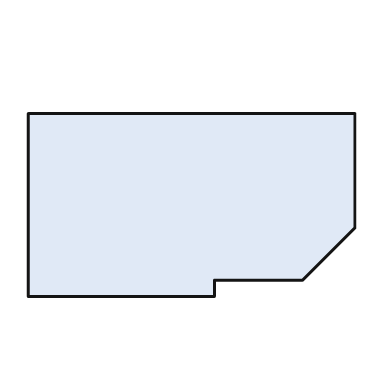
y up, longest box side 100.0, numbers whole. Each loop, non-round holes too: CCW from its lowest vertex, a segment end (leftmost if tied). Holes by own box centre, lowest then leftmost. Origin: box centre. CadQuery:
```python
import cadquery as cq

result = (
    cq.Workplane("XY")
    .moveTo(-50.0, -28.0)
    .lineTo(7.0, -28.0)
    .lineTo(7.0, -23.0)
    .lineTo(34.0, -23.0)
    .lineTo(50.0, -7.0)
    .lineTo(50.0, 28.0)
    .lineTo(-50.0, 28.0)
    .close()
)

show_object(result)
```